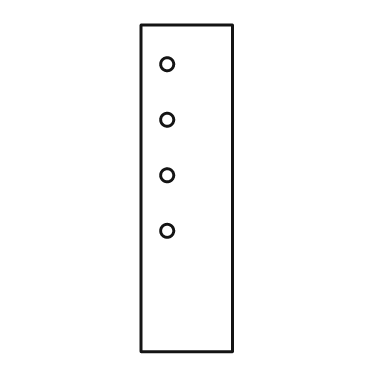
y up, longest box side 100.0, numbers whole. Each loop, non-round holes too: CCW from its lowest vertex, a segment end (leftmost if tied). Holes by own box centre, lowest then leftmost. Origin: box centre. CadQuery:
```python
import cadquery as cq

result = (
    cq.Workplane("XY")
    .moveTo(-14.0, -50.0)
    .lineTo(14.0, -50.0)
    .lineTo(14.0, 50.0)
    .lineTo(-14.0, 50.0)
    .close()
    .moveTo(-6.0, -13.0)
    .circle(2.0)
    .moveTo(-6.0, 4.0)
    .circle(2.0)
    .moveTo(-6.0, 21.0)
    .circle(2.0)
    .moveTo(-6.0, 38.0)
    .circle(2.0)
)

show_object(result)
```